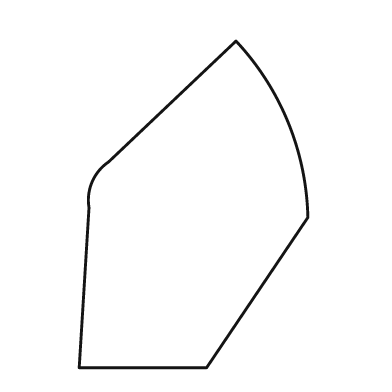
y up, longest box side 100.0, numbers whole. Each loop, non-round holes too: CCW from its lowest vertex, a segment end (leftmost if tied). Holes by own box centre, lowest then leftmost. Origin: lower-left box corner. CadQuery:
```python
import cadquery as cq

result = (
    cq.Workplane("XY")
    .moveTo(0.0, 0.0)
    .lineTo(39.0, 0.0)
    .lineTo(70.0, 46.0)
    .threePointArc((64.0, 75.0), (48.0, 100.0))
    .lineTo(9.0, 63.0)
    .threePointArc((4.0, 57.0), (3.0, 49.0))
    .close()
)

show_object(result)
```